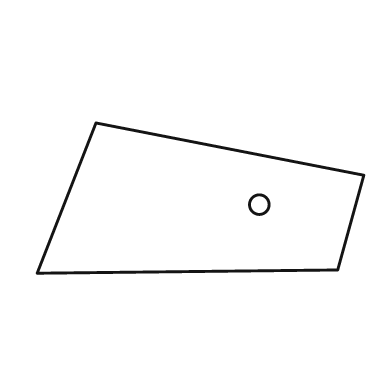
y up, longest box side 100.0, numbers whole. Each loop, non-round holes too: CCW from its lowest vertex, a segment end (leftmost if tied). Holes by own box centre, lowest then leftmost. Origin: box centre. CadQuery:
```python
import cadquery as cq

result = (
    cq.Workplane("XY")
    .moveTo(-50.0, -23.0)
    .lineTo(42.0, -22.0)
    .lineTo(50.0, 7.0)
    .lineTo(-32.0, 23.0)
    .close()
    .moveTo(18.0, -2.0)
    .circle(3.0)
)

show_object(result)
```